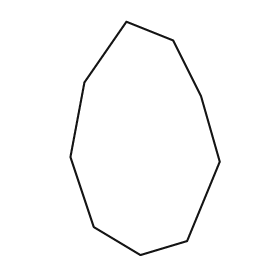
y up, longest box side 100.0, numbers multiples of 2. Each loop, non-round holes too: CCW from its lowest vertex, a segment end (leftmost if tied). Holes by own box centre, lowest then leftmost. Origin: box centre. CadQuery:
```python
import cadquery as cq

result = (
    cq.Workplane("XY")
    .moveTo(-2.0, -50.0)
    .lineTo(18.0, -44.0)
    .lineTo(32.0, -10.0)
    .lineTo(24.0, 18.0)
    .lineTo(12.0, 42.0)
    .lineTo(-8.0, 50.0)
    .lineTo(-26.0, 24.0)
    .lineTo(-32.0, -8.0)
    .lineTo(-22.0, -38.0)
    .close()
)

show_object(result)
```